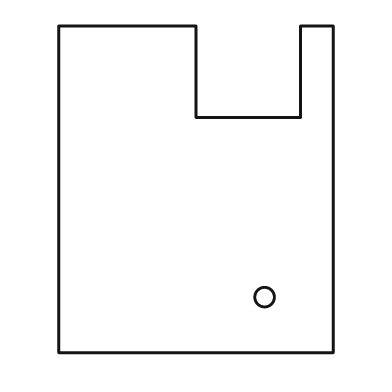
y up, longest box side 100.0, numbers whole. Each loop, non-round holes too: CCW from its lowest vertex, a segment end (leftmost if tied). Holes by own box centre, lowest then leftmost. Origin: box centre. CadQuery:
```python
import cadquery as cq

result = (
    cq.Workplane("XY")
    .moveTo(-42.0, -50.0)
    .lineTo(42.0, -50.0)
    .lineTo(42.0, 50.0)
    .lineTo(32.0, 50.0)
    .lineTo(32.0, 22.0)
    .lineTo(0.0, 22.0)
    .lineTo(0.0, 50.0)
    .lineTo(-42.0, 50.0)
    .close()
    .moveTo(21.0, -33.0)
    .circle(3.0)
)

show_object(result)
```